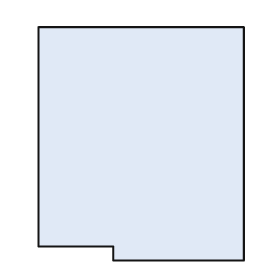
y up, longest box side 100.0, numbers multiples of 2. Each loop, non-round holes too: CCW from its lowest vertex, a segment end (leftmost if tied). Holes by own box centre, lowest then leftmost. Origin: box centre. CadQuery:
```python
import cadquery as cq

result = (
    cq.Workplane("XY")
    .moveTo(-12.0, -50.0)
    .lineTo(44.0, -50.0)
    .lineTo(44.0, 50.0)
    .lineTo(-44.0, 50.0)
    .lineTo(-44.0, -44.0)
    .lineTo(-12.0, -44.0)
    .close()
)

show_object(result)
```